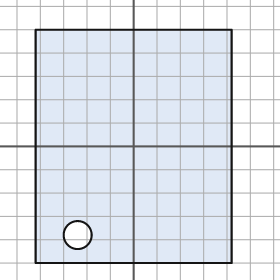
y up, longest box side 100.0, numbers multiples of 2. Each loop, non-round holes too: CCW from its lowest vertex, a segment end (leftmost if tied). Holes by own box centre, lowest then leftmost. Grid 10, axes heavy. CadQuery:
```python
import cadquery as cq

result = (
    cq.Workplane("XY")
    .moveTo(-42.0, -50.0)
    .lineTo(42.0, -50.0)
    .lineTo(42.0, 50.0)
    .lineTo(-42.0, 50.0)
    .close()
    .moveTo(-24.0, -38.0)
    .circle(6.0)
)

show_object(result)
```